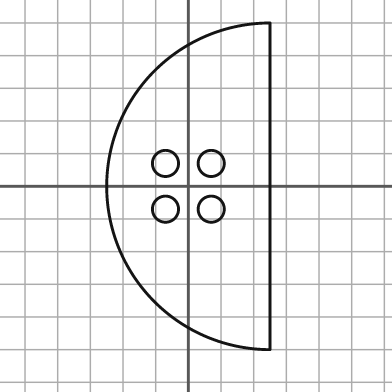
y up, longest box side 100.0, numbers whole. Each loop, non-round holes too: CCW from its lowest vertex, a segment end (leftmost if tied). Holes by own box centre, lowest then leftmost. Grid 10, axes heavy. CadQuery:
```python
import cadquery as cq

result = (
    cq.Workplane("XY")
    .moveTo(25.0, -50.0)
    .lineTo(25.0, 50.0)
    .threePointArc((-25.0, 0.0), (25.0, -50.0))
    .close()
    .moveTo(-7.0, -7.0)
    .circle(4.0)
    .moveTo(7.0, -7.0)
    .circle(4.0)
    .moveTo(-7.0, 7.0)
    .circle(4.0)
    .moveTo(7.0, 7.0)
    .circle(4.0)
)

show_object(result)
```